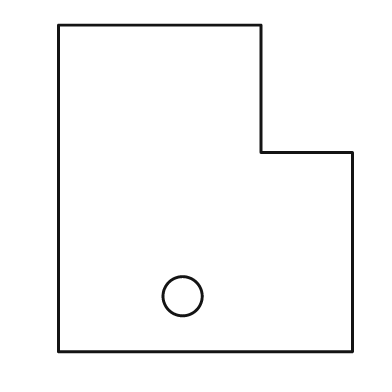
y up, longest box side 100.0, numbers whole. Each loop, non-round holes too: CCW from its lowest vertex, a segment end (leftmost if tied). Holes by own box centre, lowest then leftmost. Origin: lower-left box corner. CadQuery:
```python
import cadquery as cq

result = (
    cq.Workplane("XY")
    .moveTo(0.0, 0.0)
    .lineTo(90.0, 0.0)
    .lineTo(90.0, 61.0)
    .lineTo(62.0, 61.0)
    .lineTo(62.0, 100.0)
    .lineTo(0.0, 100.0)
    .close()
    .moveTo(38.0, 17.0)
    .circle(6.0)
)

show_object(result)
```